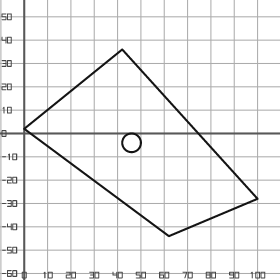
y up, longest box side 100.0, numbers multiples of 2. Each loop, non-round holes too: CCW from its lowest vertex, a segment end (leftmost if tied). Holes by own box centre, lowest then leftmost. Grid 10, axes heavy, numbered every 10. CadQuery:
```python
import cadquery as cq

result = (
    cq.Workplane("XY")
    .moveTo(62.0, -44.0)
    .lineTo(100.0, -28.0)
    .lineTo(42.0, 36.0)
    .lineTo(0.0, 2.0)
    .close()
    .moveTo(46.0, -4.0)
    .circle(4.0)
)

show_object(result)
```